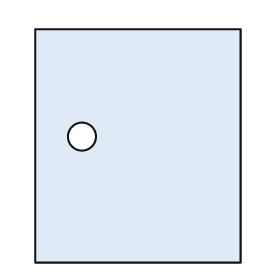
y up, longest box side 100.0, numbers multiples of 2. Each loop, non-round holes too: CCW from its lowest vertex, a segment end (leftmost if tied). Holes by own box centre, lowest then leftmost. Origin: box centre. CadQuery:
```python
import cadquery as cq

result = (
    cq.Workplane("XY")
    .moveTo(-44.0, -50.0)
    .lineTo(44.0, -50.0)
    .lineTo(44.0, 50.0)
    .lineTo(-44.0, 50.0)
    .close()
    .moveTo(-24.0, 4.0)
    .circle(6.0)
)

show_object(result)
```